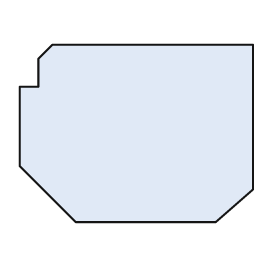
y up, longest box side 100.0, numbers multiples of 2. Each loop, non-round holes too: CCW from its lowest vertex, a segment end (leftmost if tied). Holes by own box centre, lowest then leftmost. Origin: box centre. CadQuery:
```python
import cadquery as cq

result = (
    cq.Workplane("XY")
    .moveTo(-26.0, -38.0)
    .lineTo(34.0, -38.0)
    .lineTo(50.0, -24.0)
    .lineTo(50.0, 38.0)
    .lineTo(-36.0, 38.0)
    .lineTo(-42.0, 32.0)
    .lineTo(-42.0, 20.0)
    .lineTo(-50.0, 20.0)
    .lineTo(-50.0, -14.0)
    .close()
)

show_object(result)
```